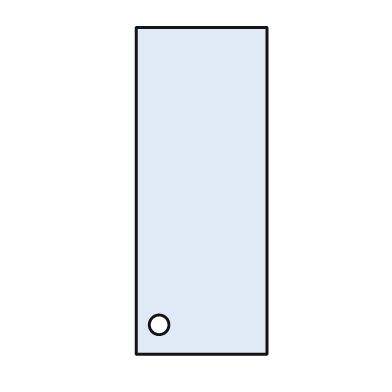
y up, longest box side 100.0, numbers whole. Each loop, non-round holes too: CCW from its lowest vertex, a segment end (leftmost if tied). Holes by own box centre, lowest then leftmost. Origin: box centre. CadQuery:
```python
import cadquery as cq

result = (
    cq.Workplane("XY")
    .moveTo(-20.0, -50.0)
    .lineTo(20.0, -50.0)
    .lineTo(20.0, 50.0)
    .lineTo(-20.0, 50.0)
    .close()
    .moveTo(-13.0, -41.0)
    .circle(3.0)
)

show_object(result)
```